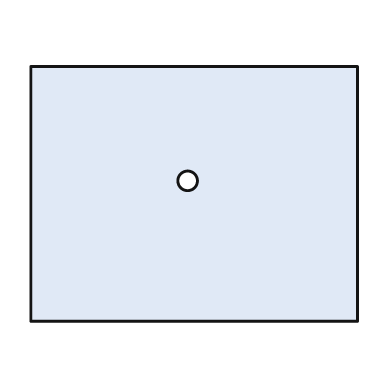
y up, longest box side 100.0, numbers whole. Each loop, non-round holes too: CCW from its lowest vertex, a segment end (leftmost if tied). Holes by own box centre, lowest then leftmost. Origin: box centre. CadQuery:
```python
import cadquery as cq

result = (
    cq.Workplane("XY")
    .moveTo(-50.0, -39.0)
    .lineTo(50.0, -39.0)
    .lineTo(50.0, 39.0)
    .lineTo(-50.0, 39.0)
    .close()
    .moveTo(-2.0, 4.0)
    .circle(3.0)
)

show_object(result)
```